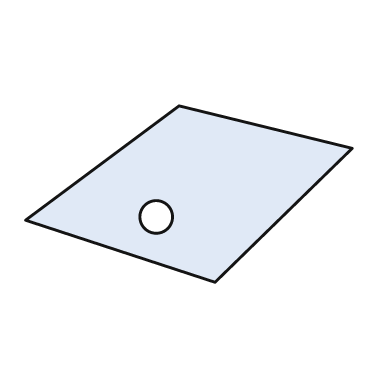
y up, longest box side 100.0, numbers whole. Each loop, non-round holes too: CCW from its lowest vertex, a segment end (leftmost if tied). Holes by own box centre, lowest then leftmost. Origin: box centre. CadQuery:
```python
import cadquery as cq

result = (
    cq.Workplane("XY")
    .moveTo(8.0, -27.0)
    .lineTo(50.0, 14.0)
    .lineTo(-3.0, 27.0)
    .lineTo(-50.0, -8.0)
    .close()
    .moveTo(-10.0, -7.0)
    .circle(5.0)
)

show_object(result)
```